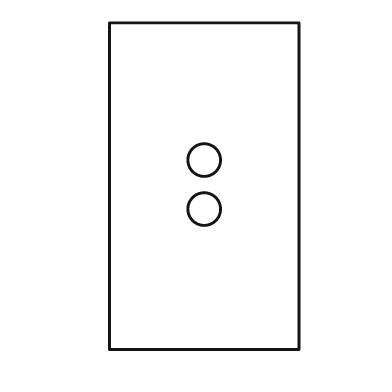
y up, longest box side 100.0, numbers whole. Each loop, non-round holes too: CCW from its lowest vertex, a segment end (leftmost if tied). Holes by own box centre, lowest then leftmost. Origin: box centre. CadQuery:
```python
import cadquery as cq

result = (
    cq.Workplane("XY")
    .moveTo(-29.0, -50.0)
    .lineTo(29.0, -50.0)
    .lineTo(29.0, 50.0)
    .lineTo(-29.0, 50.0)
    .close()
    .moveTo(0.0, -7.0)
    .circle(5.0)
    .moveTo(0.0, 8.0)
    .circle(5.0)
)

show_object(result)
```